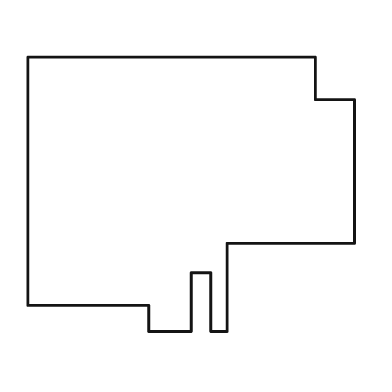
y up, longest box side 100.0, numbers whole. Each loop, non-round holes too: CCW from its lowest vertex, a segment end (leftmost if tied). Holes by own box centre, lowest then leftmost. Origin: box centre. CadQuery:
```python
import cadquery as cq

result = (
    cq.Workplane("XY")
    .moveTo(-13.0, -42.0)
    .lineTo(0.0, -42.0)
    .lineTo(0.0, -24.0)
    .lineTo(6.0, -24.0)
    .lineTo(6.0, -42.0)
    .lineTo(11.0, -42.0)
    .lineTo(11.0, -15.0)
    .lineTo(50.0, -15.0)
    .lineTo(50.0, 29.0)
    .lineTo(38.0, 29.0)
    .lineTo(38.0, 42.0)
    .lineTo(-50.0, 42.0)
    .lineTo(-50.0, -34.0)
    .lineTo(-13.0, -34.0)
    .close()
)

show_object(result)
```